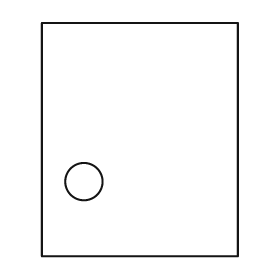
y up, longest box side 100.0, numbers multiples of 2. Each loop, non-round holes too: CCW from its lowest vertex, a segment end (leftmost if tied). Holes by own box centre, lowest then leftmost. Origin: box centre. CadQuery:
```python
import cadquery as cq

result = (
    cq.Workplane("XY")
    .moveTo(-42.0, -50.0)
    .lineTo(42.0, -50.0)
    .lineTo(42.0, 50.0)
    .lineTo(-42.0, 50.0)
    .close()
    .moveTo(-24.0, -18.0)
    .circle(8.0)
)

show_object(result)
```